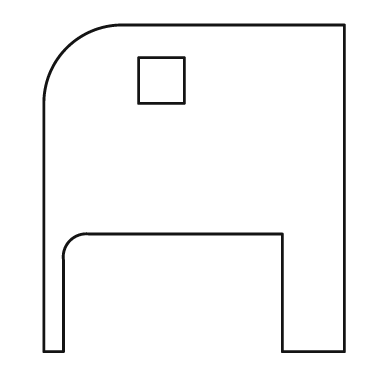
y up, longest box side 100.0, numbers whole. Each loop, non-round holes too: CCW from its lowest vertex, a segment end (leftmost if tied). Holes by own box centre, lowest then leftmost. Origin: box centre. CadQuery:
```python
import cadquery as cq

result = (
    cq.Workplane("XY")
    .moveTo(-46.0, -50.0)
    .lineTo(-40.0, -50.0)
    .lineTo(-40.0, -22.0)
    .threePointArc((-38.0, -16.0), (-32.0, -14.0))
    .lineTo(27.0, -14.0)
    .lineTo(27.0, -50.0)
    .lineTo(46.0, -50.0)
    .lineTo(46.0, 50.0)
    .lineTo(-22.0, 50.0)
    .threePointArc((-39.0, 43.0), (-46.0, 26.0))
    .close()
    .moveTo(-17.0, 26.0)
    .lineTo(-3.0, 26.0)
    .lineTo(-3.0, 40.0)
    .lineTo(-17.0, 40.0)
    .close()
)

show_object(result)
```